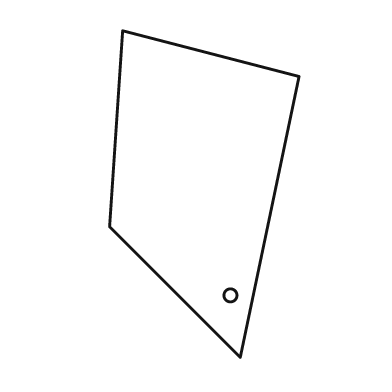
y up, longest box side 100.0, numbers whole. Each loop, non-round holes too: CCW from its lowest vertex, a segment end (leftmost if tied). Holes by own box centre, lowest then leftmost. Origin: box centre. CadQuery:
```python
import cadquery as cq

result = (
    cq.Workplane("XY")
    .moveTo(11.0, -50.0)
    .lineTo(29.0, 36.0)
    .lineTo(-25.0, 50.0)
    .lineTo(-29.0, -10.0)
    .close()
    .moveTo(8.0, -31.0)
    .circle(2.0)
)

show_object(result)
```